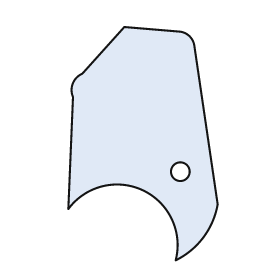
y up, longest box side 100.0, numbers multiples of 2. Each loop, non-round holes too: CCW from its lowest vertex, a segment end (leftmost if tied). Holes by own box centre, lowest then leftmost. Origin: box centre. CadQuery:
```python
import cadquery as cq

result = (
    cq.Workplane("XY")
    .moveTo(14.0, -50.0)
    .threePointArc((26.0, -40.0), (32.0, -26.0))
    .lineTo(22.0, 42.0)
    .threePointArc((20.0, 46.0), (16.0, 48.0))
    .lineTo(-8.0, 50.0)
    .lineTo(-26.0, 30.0)
    .threePointArc((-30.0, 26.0), (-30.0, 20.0))
    .lineTo(-32.0, -28.0)
    .threePointArc((0.0, -20.0), (14.0, -50.0))
    .close()
    .moveTo(16.0, -12.0)
    .circle(4.0)
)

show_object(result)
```